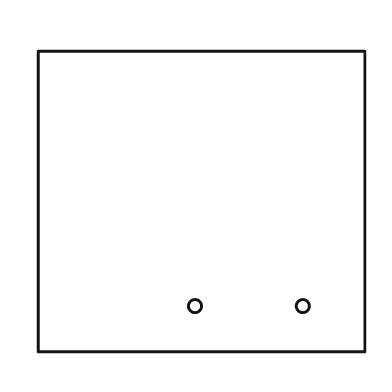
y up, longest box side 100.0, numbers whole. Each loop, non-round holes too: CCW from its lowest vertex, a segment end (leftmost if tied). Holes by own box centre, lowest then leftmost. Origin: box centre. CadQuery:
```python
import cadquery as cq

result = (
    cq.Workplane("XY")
    .moveTo(-50.0, -46.0)
    .lineTo(50.0, -46.0)
    .lineTo(50.0, 46.0)
    .lineTo(-50.0, 46.0)
    .close()
    .moveTo(-2.0, -32.0)
    .circle(2.0)
    .moveTo(31.0, -32.0)
    .circle(2.0)
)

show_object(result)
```